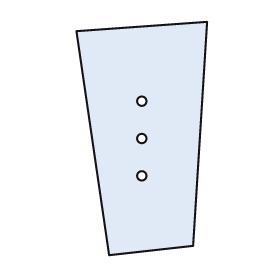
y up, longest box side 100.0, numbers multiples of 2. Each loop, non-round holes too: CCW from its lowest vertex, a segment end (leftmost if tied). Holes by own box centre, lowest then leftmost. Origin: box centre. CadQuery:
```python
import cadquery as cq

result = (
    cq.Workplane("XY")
    .moveTo(-14.0, -50.0)
    .lineTo(22.0, -46.0)
    .lineTo(28.0, 50.0)
    .lineTo(-28.0, 46.0)
    .close()
    .moveTo(0.0, -16.0)
    .circle(2.0)
    .moveTo(0.0, 0.0)
    .circle(2.0)
    .moveTo(0.0, 16.0)
    .circle(2.0)
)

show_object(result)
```